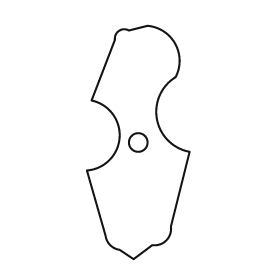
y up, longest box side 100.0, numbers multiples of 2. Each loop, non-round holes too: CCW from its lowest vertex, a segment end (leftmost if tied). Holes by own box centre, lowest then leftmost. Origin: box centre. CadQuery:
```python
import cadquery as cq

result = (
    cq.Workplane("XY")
    .moveTo(-2.0, -50.0)
    .lineTo(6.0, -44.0)
    .threePointArc((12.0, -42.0), (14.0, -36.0))
    .lineTo(22.0, -4.0)
    .threePointArc((8.0, 10.0), (16.0, 28.0))
    .threePointArc((16.0, 42.0), (4.0, 50.0))
    .lineTo(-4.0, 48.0)
    .threePointArc((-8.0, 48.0), (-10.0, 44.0))
    .lineTo(-20.0, 18.0)
    .threePointArc((-8.0, 2.0), (-22.0, -12.0))
    .lineTo(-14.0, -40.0)
    .threePointArc((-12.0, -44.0), (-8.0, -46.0))
    .close()
    .moveTo(0.0, 0.0)
    .circle(4.0)
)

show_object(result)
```